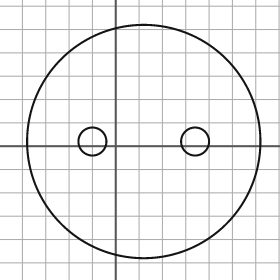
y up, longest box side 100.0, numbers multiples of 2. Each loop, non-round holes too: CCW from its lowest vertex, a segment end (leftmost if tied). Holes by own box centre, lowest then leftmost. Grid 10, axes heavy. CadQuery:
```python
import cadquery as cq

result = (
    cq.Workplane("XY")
    .moveTo(12.0, 2.0)
    .circle(50.0)
    .moveTo(-10.0, 2.0)
    .circle(6.0)
    .moveTo(34.0, 2.0)
    .circle(6.0)
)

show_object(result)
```